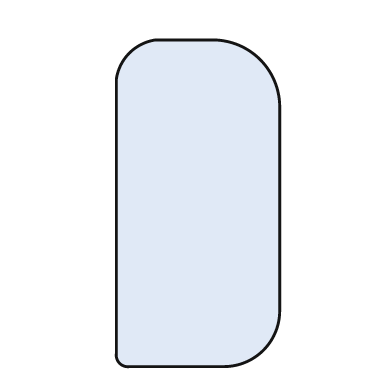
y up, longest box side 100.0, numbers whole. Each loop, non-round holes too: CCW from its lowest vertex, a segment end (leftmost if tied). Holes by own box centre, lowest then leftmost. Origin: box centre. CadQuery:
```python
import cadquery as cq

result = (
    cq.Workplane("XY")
    .moveTo(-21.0, -50.0)
    .lineTo(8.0, -50.0)
    .threePointArc((20.0, -45.0), (25.0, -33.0))
    .lineTo(25.0, 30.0)
    .threePointArc((19.0, 44.0), (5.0, 50.0))
    .lineTo(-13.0, 50.0)
    .threePointArc((-21.0, 46.0), (-25.0, 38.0))
    .lineTo(-25.0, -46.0)
    .threePointArc((-24.0, -49.0), (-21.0, -50.0))
    .close()
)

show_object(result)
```